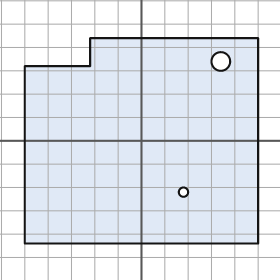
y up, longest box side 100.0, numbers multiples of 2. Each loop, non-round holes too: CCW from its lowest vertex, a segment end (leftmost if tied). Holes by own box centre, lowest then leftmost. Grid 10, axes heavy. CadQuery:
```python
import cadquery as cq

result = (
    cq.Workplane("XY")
    .moveTo(-50.0, -44.0)
    .lineTo(50.0, -44.0)
    .lineTo(50.0, 44.0)
    .lineTo(-22.0, 44.0)
    .lineTo(-22.0, 32.0)
    .lineTo(-50.0, 32.0)
    .close()
    .moveTo(18.0, -22.0)
    .circle(2.0)
    .moveTo(34.0, 34.0)
    .circle(4.0)
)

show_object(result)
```